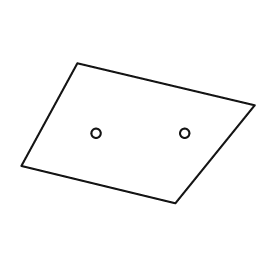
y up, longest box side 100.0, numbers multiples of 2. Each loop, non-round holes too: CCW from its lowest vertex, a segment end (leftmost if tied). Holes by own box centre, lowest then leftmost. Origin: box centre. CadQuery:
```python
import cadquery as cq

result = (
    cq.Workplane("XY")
    .moveTo(16.0, -30.0)
    .lineTo(50.0, 12.0)
    .lineTo(-26.0, 30.0)
    .lineTo(-50.0, -14.0)
    .close()
    .moveTo(-18.0, 0.0)
    .circle(2.0)
    .moveTo(20.0, 0.0)
    .circle(2.0)
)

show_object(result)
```